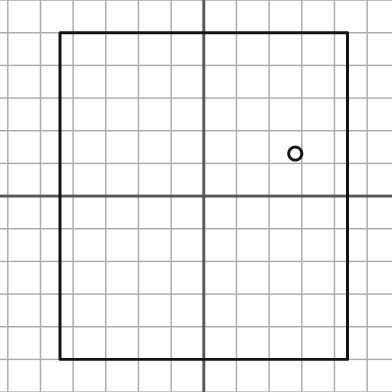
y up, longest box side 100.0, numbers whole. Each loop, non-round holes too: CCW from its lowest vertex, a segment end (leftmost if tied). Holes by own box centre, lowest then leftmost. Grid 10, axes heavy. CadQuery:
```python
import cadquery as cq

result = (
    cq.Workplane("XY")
    .moveTo(-44.0, -50.0)
    .lineTo(44.0, -50.0)
    .lineTo(44.0, 50.0)
    .lineTo(-44.0, 50.0)
    .close()
    .moveTo(28.0, 13.0)
    .circle(2.0)
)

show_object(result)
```